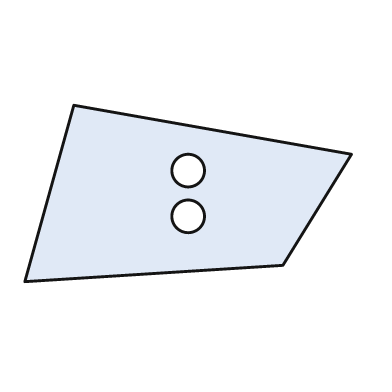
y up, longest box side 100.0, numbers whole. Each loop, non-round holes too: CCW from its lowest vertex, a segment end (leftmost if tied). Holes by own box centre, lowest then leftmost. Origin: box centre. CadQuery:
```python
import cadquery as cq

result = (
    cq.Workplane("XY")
    .moveTo(-50.0, -27.0)
    .lineTo(29.0, -22.0)
    .lineTo(50.0, 12.0)
    .lineTo(-35.0, 27.0)
    .close()
    .moveTo(0.0, -7.0)
    .circle(5.0)
    .moveTo(0.0, 7.0)
    .circle(5.0)
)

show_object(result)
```